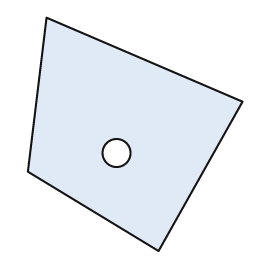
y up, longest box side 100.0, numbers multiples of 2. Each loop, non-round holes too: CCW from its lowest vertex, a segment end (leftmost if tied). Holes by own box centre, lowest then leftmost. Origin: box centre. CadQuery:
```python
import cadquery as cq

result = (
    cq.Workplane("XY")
    .moveTo(10.0, -50.0)
    .lineTo(46.0, 14.0)
    .lineTo(-38.0, 50.0)
    .lineTo(-46.0, -16.0)
    .close()
    .moveTo(-8.0, -8.0)
    .circle(6.0)
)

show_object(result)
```